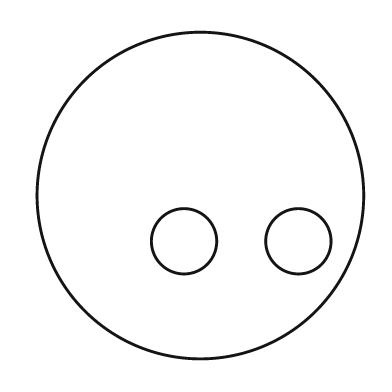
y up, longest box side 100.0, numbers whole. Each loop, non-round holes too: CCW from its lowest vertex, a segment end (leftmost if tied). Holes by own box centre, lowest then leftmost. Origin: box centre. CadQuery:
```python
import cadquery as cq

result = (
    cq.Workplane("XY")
    .moveTo(0.0, 0.0)
    .circle(50.0)
    .moveTo(-5.0, -14.0)
    .circle(10.0)
    .moveTo(30.0, -14.0)
    .circle(10.0)
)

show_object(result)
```